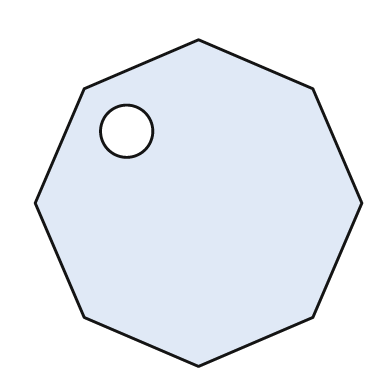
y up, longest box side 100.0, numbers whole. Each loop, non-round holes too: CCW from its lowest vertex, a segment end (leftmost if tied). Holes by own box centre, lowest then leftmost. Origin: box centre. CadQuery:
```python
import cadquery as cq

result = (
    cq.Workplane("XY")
    .moveTo(0.0, -50.0)
    .lineTo(35.0, -35.0)
    .lineTo(50.0, 0.0)
    .lineTo(35.0, 35.0)
    .lineTo(0.0, 50.0)
    .lineTo(-35.0, 35.0)
    .lineTo(-50.0, 0.0)
    .lineTo(-35.0, -35.0)
    .close()
    .moveTo(-22.0, 22.0)
    .circle(8.0)
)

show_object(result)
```